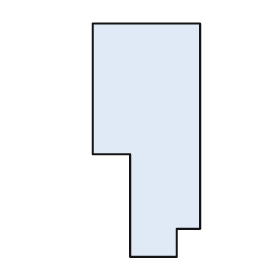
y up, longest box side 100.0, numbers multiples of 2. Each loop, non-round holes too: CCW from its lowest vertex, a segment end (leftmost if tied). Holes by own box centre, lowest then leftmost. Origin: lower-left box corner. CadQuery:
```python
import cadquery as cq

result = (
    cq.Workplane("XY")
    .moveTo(16.0, 0.0)
    .lineTo(36.0, 0.0)
    .lineTo(36.0, 12.0)
    .lineTo(46.0, 12.0)
    .lineTo(46.0, 100.0)
    .lineTo(0.0, 100.0)
    .lineTo(0.0, 44.0)
    .lineTo(16.0, 44.0)
    .close()
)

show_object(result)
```